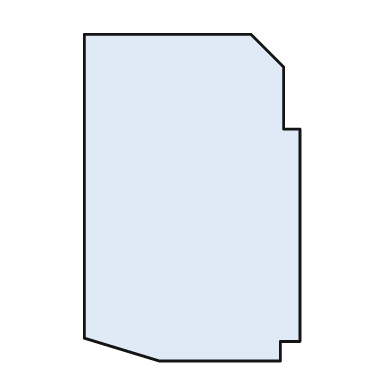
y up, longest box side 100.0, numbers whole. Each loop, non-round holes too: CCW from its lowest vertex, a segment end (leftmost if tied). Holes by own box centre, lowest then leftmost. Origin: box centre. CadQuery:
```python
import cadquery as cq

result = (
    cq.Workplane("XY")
    .moveTo(-10.0, -50.0)
    .lineTo(27.0, -50.0)
    .lineTo(27.0, -44.0)
    .lineTo(33.0, -44.0)
    .lineTo(33.0, 21.0)
    .lineTo(28.0, 21.0)
    .lineTo(28.0, 40.0)
    .lineTo(18.0, 50.0)
    .lineTo(-33.0, 50.0)
    .lineTo(-33.0, -43.0)
    .close()
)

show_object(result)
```